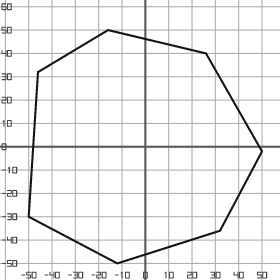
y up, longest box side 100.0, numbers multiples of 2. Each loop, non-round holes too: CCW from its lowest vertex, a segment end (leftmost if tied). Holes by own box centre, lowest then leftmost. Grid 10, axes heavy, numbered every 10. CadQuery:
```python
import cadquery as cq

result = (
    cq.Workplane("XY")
    .moveTo(-12.0, -50.0)
    .lineTo(32.0, -36.0)
    .lineTo(50.0, -2.0)
    .lineTo(26.0, 40.0)
    .lineTo(-16.0, 50.0)
    .lineTo(-46.0, 32.0)
    .lineTo(-50.0, -30.0)
    .close()
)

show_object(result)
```